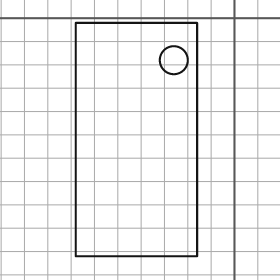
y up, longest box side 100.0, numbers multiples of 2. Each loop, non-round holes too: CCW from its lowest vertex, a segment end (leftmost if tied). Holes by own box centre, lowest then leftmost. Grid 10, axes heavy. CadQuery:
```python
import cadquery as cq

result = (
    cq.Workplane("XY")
    .moveTo(-68.0, -102.0)
    .lineTo(-16.0, -102.0)
    .lineTo(-16.0, -2.0)
    .lineTo(-68.0, -2.0)
    .close()
    .moveTo(-26.0, -18.0)
    .circle(6.0)
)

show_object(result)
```